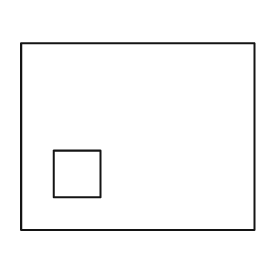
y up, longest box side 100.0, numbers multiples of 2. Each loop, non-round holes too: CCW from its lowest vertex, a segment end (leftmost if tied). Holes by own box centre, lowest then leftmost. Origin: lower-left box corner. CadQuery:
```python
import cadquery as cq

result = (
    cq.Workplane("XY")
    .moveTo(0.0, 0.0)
    .lineTo(100.0, 0.0)
    .lineTo(100.0, 80.0)
    .lineTo(0.0, 80.0)
    .close()
    .moveTo(14.0, 14.0)
    .lineTo(34.0, 14.0)
    .lineTo(34.0, 34.0)
    .lineTo(14.0, 34.0)
    .close()
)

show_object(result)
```